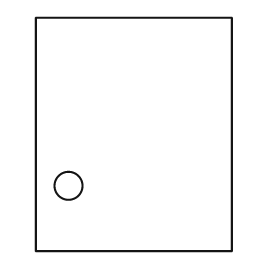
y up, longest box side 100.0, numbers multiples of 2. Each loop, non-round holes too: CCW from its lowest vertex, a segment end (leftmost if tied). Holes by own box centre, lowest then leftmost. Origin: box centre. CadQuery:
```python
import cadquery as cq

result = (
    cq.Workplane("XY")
    .moveTo(-42.0, -50.0)
    .lineTo(42.0, -50.0)
    .lineTo(42.0, 50.0)
    .lineTo(-42.0, 50.0)
    .close()
    .moveTo(-28.0, -22.0)
    .circle(6.0)
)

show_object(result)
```